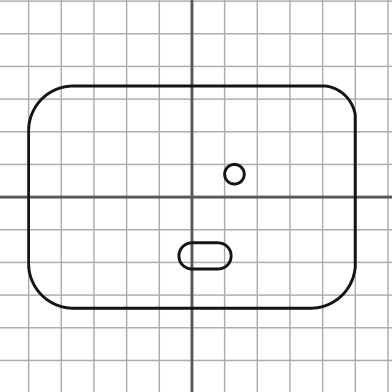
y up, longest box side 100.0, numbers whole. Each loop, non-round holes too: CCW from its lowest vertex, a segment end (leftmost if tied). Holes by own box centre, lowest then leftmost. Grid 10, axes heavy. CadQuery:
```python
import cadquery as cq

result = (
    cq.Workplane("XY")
    .moveTo(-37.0, -34.0)
    .lineTo(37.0, -34.0)
    .threePointArc((46.0, -30.0), (50.0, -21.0))
    .lineTo(50.0, 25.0)
    .threePointArc((47.0, 31.0), (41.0, 34.0))
    .lineTo(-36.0, 34.0)
    .threePointArc((-46.0, 30.0), (-50.0, 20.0))
    .lineTo(-50.0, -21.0)
    .threePointArc((-46.0, -30.0), (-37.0, -34.0))
    .close()
    .moveTo(0.0, -22.0)
    .lineTo(8.0, -22.0)
    .threePointArc((12.0, -18.0), (8.0, -14.0))
    .lineTo(0.0, -14.0)
    .threePointArc((-4.0, -18.0), (0.0, -22.0))
    .close()
    .moveTo(13.0, 7.0)
    .circle(3.0)
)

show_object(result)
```